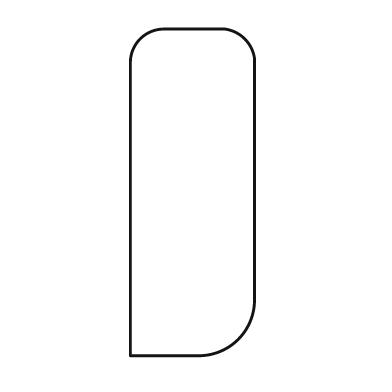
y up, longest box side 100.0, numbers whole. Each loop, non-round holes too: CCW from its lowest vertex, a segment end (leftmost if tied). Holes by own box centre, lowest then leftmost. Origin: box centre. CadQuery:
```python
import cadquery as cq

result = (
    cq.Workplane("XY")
    .moveTo(-19.0, -50.0)
    .lineTo(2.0, -50.0)
    .threePointArc((14.0, -45.0), (19.0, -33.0))
    .lineTo(19.0, 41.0)
    .threePointArc((16.0, 47.0), (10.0, 50.0))
    .lineTo(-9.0, 50.0)
    .threePointArc((-16.0, 47.0), (-19.0, 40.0))
    .close()
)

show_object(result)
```